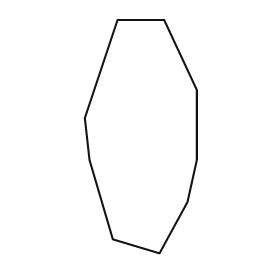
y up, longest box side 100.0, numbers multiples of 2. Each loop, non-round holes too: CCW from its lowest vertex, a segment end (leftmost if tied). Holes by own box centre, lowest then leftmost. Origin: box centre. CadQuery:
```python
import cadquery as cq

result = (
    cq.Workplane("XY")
    .moveTo(8.0, -50.0)
    .lineTo(20.0, -28.0)
    .lineTo(24.0, -10.0)
    .lineTo(24.0, 20.0)
    .lineTo(10.0, 50.0)
    .lineTo(-10.0, 50.0)
    .lineTo(-24.0, 8.0)
    .lineTo(-22.0, -10.0)
    .lineTo(-12.0, -44.0)
    .close()
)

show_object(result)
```